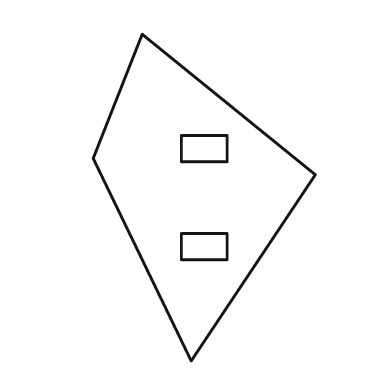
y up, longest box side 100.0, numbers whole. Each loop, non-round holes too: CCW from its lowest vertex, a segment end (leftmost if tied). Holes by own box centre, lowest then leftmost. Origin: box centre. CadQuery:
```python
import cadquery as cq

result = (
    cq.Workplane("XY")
    .moveTo(-4.0, -50.0)
    .lineTo(34.0, 7.0)
    .lineTo(-19.0, 50.0)
    .lineTo(-34.0, 12.0)
    .close()
    .moveTo(-7.0, -19.0)
    .lineTo(7.0, -19.0)
    .lineTo(7.0, -11.0)
    .lineTo(-7.0, -11.0)
    .close()
    .moveTo(-7.0, 11.0)
    .lineTo(7.0, 11.0)
    .lineTo(7.0, 19.0)
    .lineTo(-7.0, 19.0)
    .close()
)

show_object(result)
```